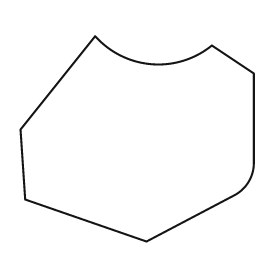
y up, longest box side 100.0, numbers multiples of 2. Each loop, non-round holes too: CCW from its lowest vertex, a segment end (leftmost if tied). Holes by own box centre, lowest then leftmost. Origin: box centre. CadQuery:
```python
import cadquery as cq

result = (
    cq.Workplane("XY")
    .moveTo(4.0, -44.0)
    .lineTo(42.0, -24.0)
    .threePointArc((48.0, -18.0), (50.0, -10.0))
    .lineTo(50.0, 28.0)
    .lineTo(32.0, 40.0)
    .threePointArc((6.0, 32.0), (-18.0, 44.0))
    .lineTo(-50.0, 4.0)
    .lineTo(-48.0, -26.0)
    .close()
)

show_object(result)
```